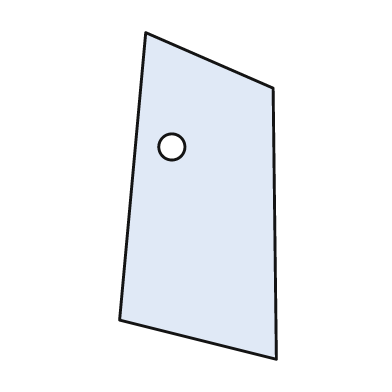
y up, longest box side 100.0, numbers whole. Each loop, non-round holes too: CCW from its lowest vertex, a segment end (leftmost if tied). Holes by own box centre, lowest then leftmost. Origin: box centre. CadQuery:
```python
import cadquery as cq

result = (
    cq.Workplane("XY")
    .moveTo(24.0, -50.0)
    .lineTo(23.0, 33.0)
    .lineTo(-16.0, 50.0)
    .lineTo(-24.0, -38.0)
    .close()
    .moveTo(-8.0, 15.0)
    .circle(4.0)
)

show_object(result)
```